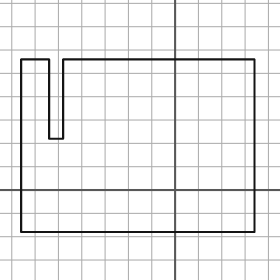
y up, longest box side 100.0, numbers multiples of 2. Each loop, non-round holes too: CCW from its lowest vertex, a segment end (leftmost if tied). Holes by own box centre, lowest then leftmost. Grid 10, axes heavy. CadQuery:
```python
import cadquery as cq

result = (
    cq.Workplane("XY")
    .moveTo(-66.0, -18.0)
    .lineTo(34.0, -18.0)
    .lineTo(34.0, 56.0)
    .lineTo(-48.0, 56.0)
    .lineTo(-48.0, 22.0)
    .lineTo(-54.0, 22.0)
    .lineTo(-54.0, 56.0)
    .lineTo(-66.0, 56.0)
    .close()
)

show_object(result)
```